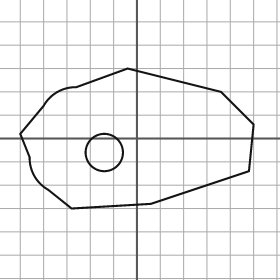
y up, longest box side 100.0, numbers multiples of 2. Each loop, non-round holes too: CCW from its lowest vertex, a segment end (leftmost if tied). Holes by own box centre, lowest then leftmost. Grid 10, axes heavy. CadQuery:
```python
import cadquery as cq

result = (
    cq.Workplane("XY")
    .moveTo(-28.0, -30.0)
    .lineTo(6.0, -28.0)
    .lineTo(48.0, -14.0)
    .lineTo(50.0, 6.0)
    .lineTo(36.0, 20.0)
    .lineTo(-4.0, 30.0)
    .lineTo(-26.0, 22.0)
    .threePointArc((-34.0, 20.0), (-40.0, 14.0))
    .lineTo(-50.0, 2.0)
    .lineTo(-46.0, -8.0)
    .threePointArc((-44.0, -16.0), (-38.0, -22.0))
    .close()
    .moveTo(-14.0, -6.0)
    .circle(8.0)
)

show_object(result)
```